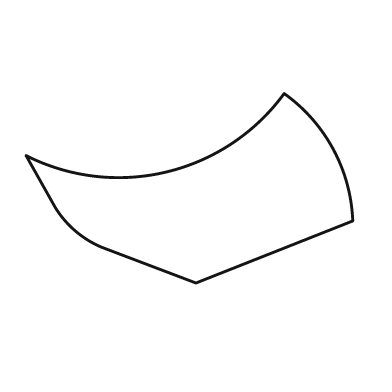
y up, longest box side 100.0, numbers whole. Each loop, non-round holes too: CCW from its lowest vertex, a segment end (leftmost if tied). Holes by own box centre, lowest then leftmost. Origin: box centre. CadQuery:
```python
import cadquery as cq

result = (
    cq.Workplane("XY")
    .moveTo(2.0, -29.0)
    .lineTo(50.0, -10.0)
    .threePointArc((44.0, 12.0), (29.0, 29.0))
    .threePointArc((-7.0, 5.0), (-50.0, 10.0))
    .lineTo(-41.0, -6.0)
    .threePointArc((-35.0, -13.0), (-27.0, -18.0))
    .close()
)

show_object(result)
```